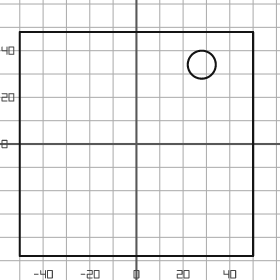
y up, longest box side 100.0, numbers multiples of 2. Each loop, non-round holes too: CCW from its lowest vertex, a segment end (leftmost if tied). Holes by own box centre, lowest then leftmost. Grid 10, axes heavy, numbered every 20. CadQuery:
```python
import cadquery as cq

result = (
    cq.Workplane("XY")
    .moveTo(-50.0, -48.0)
    .lineTo(50.0, -48.0)
    .lineTo(50.0, 48.0)
    .lineTo(-50.0, 48.0)
    .close()
    .moveTo(28.0, 34.0)
    .circle(6.0)
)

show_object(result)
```